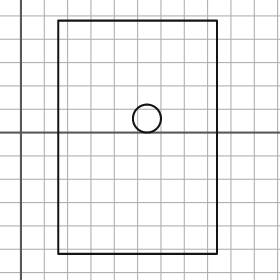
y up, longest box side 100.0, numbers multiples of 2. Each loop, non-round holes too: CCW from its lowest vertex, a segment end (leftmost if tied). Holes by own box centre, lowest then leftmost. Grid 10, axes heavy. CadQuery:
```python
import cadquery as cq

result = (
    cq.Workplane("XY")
    .moveTo(16.0, -52.0)
    .lineTo(84.0, -52.0)
    .lineTo(84.0, 48.0)
    .lineTo(16.0, 48.0)
    .close()
    .moveTo(54.0, 6.0)
    .circle(6.0)
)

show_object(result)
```